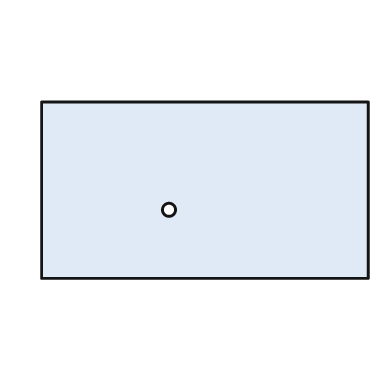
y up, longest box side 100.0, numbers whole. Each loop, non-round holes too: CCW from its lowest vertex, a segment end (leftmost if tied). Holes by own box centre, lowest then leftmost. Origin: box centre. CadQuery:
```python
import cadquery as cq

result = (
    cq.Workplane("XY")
    .moveTo(-50.0, -27.0)
    .lineTo(50.0, -27.0)
    .lineTo(50.0, 27.0)
    .lineTo(-50.0, 27.0)
    .close()
    .moveTo(-11.0, -6.0)
    .circle(2.0)
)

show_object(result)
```